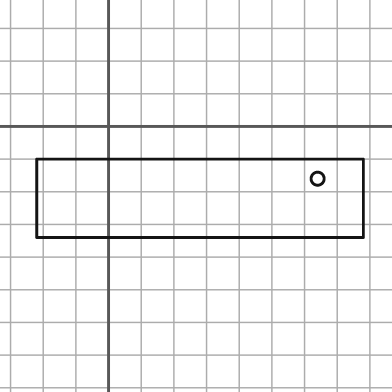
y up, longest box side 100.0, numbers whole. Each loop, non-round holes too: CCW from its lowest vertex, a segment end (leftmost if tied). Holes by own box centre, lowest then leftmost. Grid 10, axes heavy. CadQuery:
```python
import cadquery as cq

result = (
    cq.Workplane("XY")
    .moveTo(-22.0, -34.0)
    .lineTo(78.0, -34.0)
    .lineTo(78.0, -10.0)
    .lineTo(-22.0, -10.0)
    .close()
    .moveTo(64.0, -16.0)
    .circle(2.0)
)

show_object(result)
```